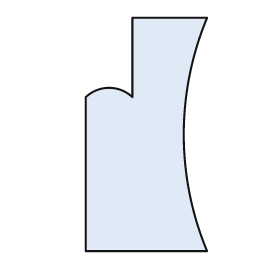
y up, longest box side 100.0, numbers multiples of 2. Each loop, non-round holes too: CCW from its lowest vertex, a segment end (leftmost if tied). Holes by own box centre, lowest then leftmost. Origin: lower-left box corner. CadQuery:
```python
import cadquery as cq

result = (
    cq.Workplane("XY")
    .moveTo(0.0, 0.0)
    .lineTo(52.0, 0.0)
    .threePointArc((42.0, 50.0), (52.0, 100.0))
    .lineTo(20.0, 100.0)
    .lineTo(20.0, 66.0)
    .threePointArc((10.0, 70.0), (0.0, 66.0))
    .close()
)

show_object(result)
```